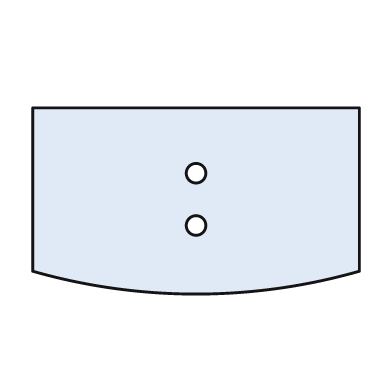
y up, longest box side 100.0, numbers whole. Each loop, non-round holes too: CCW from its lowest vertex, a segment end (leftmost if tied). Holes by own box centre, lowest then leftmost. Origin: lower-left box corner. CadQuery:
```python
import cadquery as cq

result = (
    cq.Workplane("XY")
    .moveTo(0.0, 7.0)
    .threePointArc((50.0, 0.0), (100.0, 7.0))
    .lineTo(100.0, 57.0)
    .lineTo(0.0, 57.0)
    .close()
    .moveTo(50.0, 21.0)
    .circle(3.0)
    .moveTo(50.0, 37.0)
    .circle(3.0)
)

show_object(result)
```